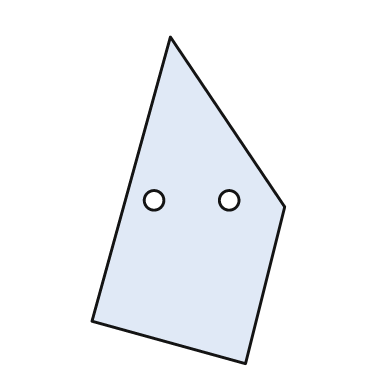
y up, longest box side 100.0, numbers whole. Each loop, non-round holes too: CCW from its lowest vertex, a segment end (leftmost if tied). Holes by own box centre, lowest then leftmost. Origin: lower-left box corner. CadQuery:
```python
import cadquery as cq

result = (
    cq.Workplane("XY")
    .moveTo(47.0, 0.0)
    .lineTo(59.0, 48.0)
    .lineTo(24.0, 100.0)
    .lineTo(0.0, 13.0)
    .close()
    .moveTo(19.0, 50.0)
    .circle(3.0)
    .moveTo(42.0, 50.0)
    .circle(3.0)
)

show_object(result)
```